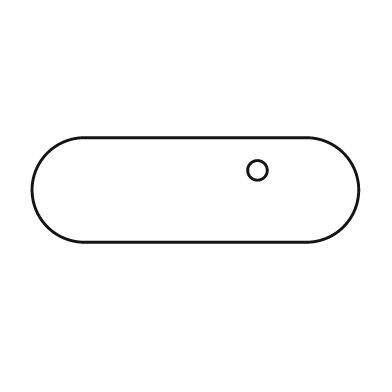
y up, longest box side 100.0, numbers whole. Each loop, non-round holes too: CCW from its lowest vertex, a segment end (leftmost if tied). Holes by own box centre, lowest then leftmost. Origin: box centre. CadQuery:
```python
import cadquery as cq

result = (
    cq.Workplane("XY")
    .moveTo(-34.0, -16.0)
    .lineTo(34.0, -16.0)
    .threePointArc((50.0, 0.0), (34.0, 16.0))
    .lineTo(-34.0, 16.0)
    .threePointArc((-50.0, 0.0), (-34.0, -16.0))
    .close()
    .moveTo(19.0, 6.0)
    .circle(3.0)
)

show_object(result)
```